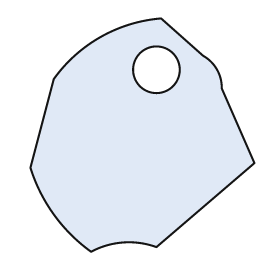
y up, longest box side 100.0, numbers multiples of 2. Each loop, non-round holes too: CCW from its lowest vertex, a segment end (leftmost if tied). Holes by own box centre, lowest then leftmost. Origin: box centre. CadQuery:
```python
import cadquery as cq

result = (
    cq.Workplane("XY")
    .moveTo(-22.0, -50.0)
    .threePointArc((-8.0, -46.0), (6.0, -48.0))
    .lineTo(48.0, -12.0)
    .lineTo(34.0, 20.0)
    .threePointArc((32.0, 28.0), (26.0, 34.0))
    .lineTo(8.0, 50.0)
    .threePointArc((-18.0, 42.0), (-38.0, 24.0))
    .lineTo(-48.0, -14.0)
    .threePointArc((-38.0, -34.0), (-22.0, -50.0))
    .close()
    .moveTo(6.0, 28.0)
    .circle(10.0)
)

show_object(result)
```